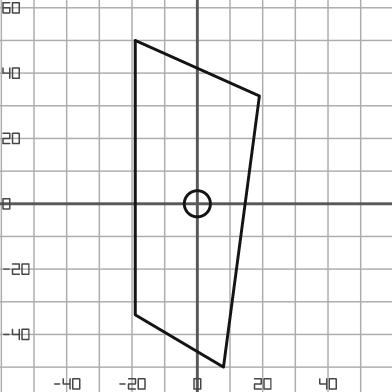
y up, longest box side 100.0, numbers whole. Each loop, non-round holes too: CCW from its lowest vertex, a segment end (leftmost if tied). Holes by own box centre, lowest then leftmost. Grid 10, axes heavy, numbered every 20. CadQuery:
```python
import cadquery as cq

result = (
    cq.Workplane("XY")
    .moveTo(8.0, -50.0)
    .lineTo(19.0, 33.0)
    .lineTo(-19.0, 50.0)
    .lineTo(-19.0, -34.0)
    .close()
    .moveTo(0.0, 0.0)
    .circle(4.0)
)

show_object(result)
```